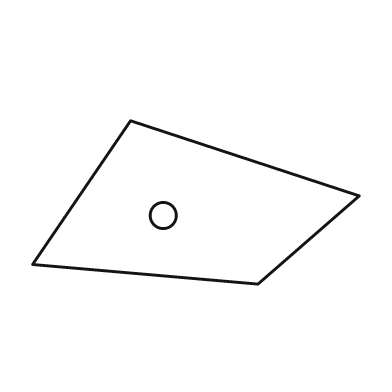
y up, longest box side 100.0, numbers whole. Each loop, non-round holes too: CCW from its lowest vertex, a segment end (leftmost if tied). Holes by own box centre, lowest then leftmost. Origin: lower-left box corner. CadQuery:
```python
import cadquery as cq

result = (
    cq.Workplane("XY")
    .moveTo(69.0, 0.0)
    .lineTo(100.0, 27.0)
    .lineTo(30.0, 50.0)
    .lineTo(0.0, 6.0)
    .close()
    .moveTo(40.0, 21.0)
    .circle(4.0)
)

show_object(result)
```